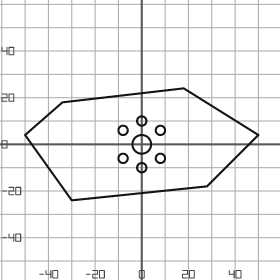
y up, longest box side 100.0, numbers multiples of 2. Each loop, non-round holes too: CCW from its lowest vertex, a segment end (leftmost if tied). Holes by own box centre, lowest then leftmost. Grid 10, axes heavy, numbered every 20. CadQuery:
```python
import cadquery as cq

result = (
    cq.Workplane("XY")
    .moveTo(-30.0, -24.0)
    .lineTo(28.0, -18.0)
    .lineTo(50.0, 4.0)
    .lineTo(18.0, 24.0)
    .lineTo(-34.0, 18.0)
    .lineTo(-50.0, 4.0)
    .close()
    .moveTo(0.0, -10.0)
    .circle(2.0)
    .moveTo(-8.0, -6.0)
    .circle(2.0)
    .moveTo(8.0, -6.0)
    .circle(2.0)
    .moveTo(0.0, 0.0)
    .circle(4.0)
    .moveTo(-8.0, 6.0)
    .circle(2.0)
    .moveTo(8.0, 6.0)
    .circle(2.0)
    .moveTo(0.0, 10.0)
    .circle(2.0)
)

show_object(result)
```